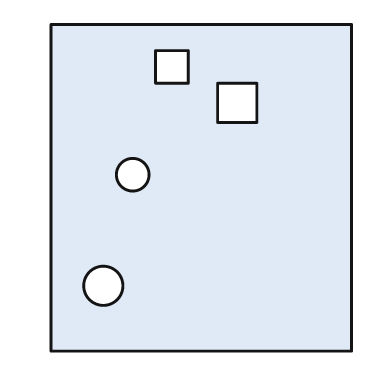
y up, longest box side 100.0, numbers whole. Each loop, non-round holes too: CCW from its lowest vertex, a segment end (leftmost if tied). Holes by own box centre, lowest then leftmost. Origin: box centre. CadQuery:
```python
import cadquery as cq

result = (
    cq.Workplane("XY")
    .moveTo(-46.0, -50.0)
    .lineTo(46.0, -50.0)
    .lineTo(46.0, 50.0)
    .lineTo(-46.0, 50.0)
    .close()
    .moveTo(-30.0, -30.0)
    .circle(6.0)
    .moveTo(-21.0, 4.0)
    .circle(5.0)
    .moveTo(5.0, 20.0)
    .lineTo(17.0, 20.0)
    .lineTo(17.0, 32.0)
    .lineTo(5.0, 32.0)
    .close()
    .moveTo(-14.0, 32.0)
    .lineTo(-4.0, 32.0)
    .lineTo(-4.0, 42.0)
    .lineTo(-14.0, 42.0)
    .close()
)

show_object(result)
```